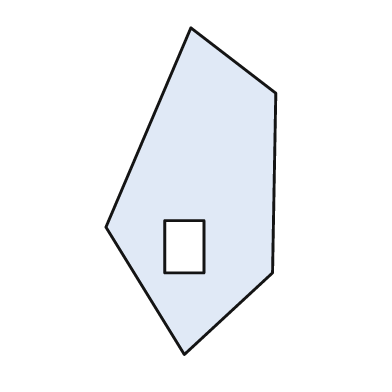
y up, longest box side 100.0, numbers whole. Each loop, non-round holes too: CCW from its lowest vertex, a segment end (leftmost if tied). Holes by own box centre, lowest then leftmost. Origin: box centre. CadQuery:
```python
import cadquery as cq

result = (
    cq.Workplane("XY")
    .moveTo(-2.0, -50.0)
    .lineTo(25.0, -25.0)
    .lineTo(26.0, 30.0)
    .lineTo(0.0, 50.0)
    .lineTo(-26.0, -11.0)
    .close()
    .moveTo(-8.0, -25.0)
    .lineTo(4.0, -25.0)
    .lineTo(4.0, -9.0)
    .lineTo(-8.0, -9.0)
    .close()
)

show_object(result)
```